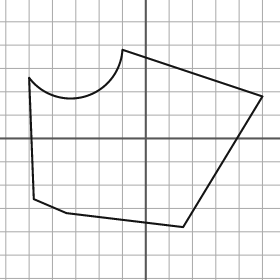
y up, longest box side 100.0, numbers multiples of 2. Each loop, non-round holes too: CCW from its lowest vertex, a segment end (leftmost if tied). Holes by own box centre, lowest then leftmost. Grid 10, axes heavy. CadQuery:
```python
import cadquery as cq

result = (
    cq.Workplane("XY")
    .moveTo(16.0, -38.0)
    .lineTo(50.0, 18.0)
    .lineTo(-10.0, 38.0)
    .threePointArc((-26.0, 18.0), (-50.0, 26.0))
    .lineTo(-48.0, -26.0)
    .lineTo(-34.0, -32.0)
    .close()
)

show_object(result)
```